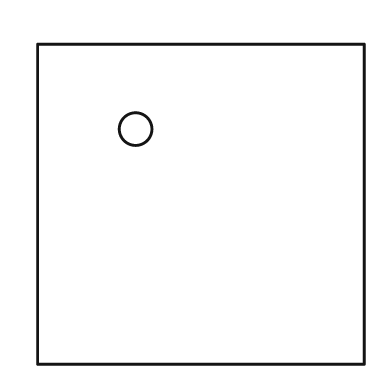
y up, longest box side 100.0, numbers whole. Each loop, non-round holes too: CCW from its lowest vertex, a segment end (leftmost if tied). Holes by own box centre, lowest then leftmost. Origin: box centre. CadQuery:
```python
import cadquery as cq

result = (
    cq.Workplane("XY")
    .moveTo(-50.0, -49.0)
    .lineTo(50.0, -49.0)
    .lineTo(50.0, 49.0)
    .lineTo(-50.0, 49.0)
    .close()
    .moveTo(-20.0, 23.0)
    .circle(5.0)
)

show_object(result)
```